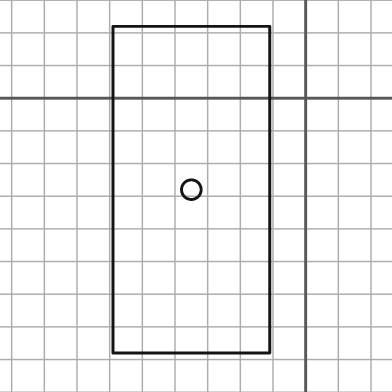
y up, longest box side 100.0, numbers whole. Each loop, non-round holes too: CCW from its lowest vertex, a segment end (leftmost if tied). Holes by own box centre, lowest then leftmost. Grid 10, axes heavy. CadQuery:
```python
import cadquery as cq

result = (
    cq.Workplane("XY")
    .moveTo(-59.0, -78.0)
    .lineTo(-11.0, -78.0)
    .lineTo(-11.0, 22.0)
    .lineTo(-59.0, 22.0)
    .close()
    .moveTo(-35.0, -28.0)
    .circle(3.0)
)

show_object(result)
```